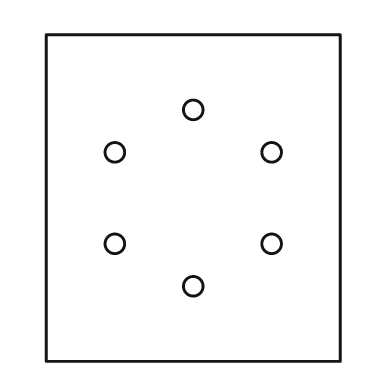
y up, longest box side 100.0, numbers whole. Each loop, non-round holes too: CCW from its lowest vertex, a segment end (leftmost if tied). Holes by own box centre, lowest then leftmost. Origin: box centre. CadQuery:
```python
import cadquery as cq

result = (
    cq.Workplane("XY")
    .moveTo(-45.0, -50.0)
    .lineTo(45.0, -50.0)
    .lineTo(45.0, 50.0)
    .lineTo(-45.0, 50.0)
    .close()
    .moveTo(0.0, -27.0)
    .circle(3.0)
    .moveTo(-24.0, -14.0)
    .circle(3.0)
    .moveTo(24.0, -14.0)
    .circle(3.0)
    .moveTo(-24.0, 14.0)
    .circle(3.0)
    .moveTo(24.0, 14.0)
    .circle(3.0)
    .moveTo(0.0, 27.0)
    .circle(3.0)
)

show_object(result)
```